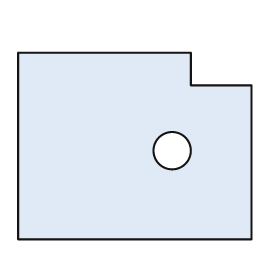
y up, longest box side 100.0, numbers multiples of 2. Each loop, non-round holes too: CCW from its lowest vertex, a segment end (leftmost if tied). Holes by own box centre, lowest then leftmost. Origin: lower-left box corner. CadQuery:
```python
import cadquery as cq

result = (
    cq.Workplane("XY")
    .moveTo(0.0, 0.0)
    .lineTo(100.0, 0.0)
    .lineTo(100.0, 66.0)
    .lineTo(74.0, 66.0)
    .lineTo(74.0, 80.0)
    .lineTo(0.0, 80.0)
    .close()
    .moveTo(66.0, 38.0)
    .circle(8.0)
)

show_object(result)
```